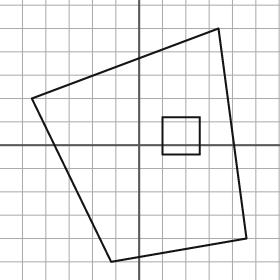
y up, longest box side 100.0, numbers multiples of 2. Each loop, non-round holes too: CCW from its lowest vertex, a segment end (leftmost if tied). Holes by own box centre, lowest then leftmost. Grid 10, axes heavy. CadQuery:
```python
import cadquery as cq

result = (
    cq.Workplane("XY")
    .moveTo(-12.0, -50.0)
    .lineTo(46.0, -40.0)
    .lineTo(34.0, 50.0)
    .lineTo(-46.0, 20.0)
    .close()
    .moveTo(10.0, -4.0)
    .lineTo(26.0, -4.0)
    .lineTo(26.0, 12.0)
    .lineTo(10.0, 12.0)
    .close()
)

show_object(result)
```